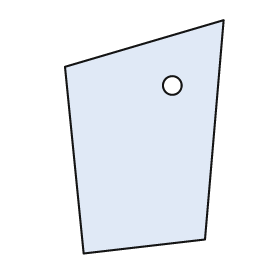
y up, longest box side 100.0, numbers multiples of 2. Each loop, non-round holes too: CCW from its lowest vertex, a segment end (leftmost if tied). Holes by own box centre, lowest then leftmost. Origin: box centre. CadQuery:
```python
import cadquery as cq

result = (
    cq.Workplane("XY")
    .moveTo(-26.0, -50.0)
    .lineTo(26.0, -44.0)
    .lineTo(34.0, 50.0)
    .lineTo(-34.0, 30.0)
    .close()
    .moveTo(12.0, 22.0)
    .circle(4.0)
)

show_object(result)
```